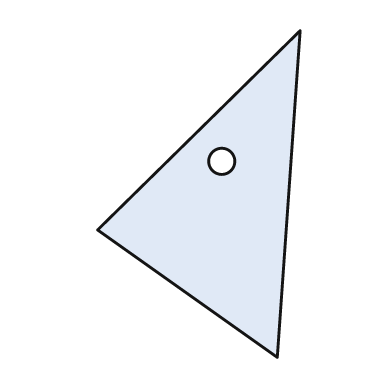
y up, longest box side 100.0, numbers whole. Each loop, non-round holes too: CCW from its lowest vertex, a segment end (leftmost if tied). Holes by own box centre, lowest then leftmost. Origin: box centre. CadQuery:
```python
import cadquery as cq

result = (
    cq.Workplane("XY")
    .moveTo(24.0, -50.0)
    .lineTo(31.0, 50.0)
    .lineTo(-31.0, -11.0)
    .close()
    .moveTo(7.0, 10.0)
    .circle(4.0)
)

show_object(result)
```